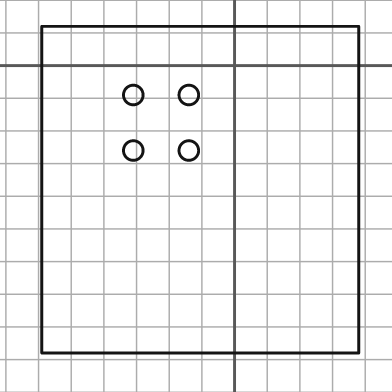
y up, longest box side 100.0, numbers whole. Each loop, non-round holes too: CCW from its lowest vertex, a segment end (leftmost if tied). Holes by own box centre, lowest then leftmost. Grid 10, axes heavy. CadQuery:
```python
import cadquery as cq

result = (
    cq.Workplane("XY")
    .moveTo(-59.0, -88.0)
    .lineTo(38.0, -88.0)
    .lineTo(38.0, 12.0)
    .lineTo(-59.0, 12.0)
    .close()
    .moveTo(-31.0, -26.0)
    .circle(3.0)
    .moveTo(-14.0, -26.0)
    .circle(3.0)
    .moveTo(-31.0, -9.0)
    .circle(3.0)
    .moveTo(-14.0, -9.0)
    .circle(3.0)
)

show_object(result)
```